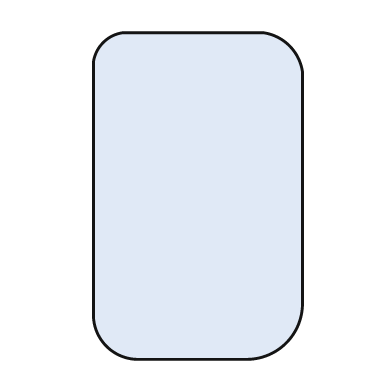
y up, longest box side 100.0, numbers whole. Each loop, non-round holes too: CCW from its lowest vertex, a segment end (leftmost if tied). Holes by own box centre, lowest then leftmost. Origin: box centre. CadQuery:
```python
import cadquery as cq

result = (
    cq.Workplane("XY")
    .moveTo(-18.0, -50.0)
    .lineTo(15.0, -50.0)
    .threePointArc((27.0, -45.0), (32.0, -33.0))
    .lineTo(32.0, 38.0)
    .threePointArc((28.0, 46.0), (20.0, 50.0))
    .lineTo(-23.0, 50.0)
    .threePointArc((-29.0, 47.0), (-32.0, 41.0))
    .lineTo(-32.0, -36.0)
    .threePointArc((-28.0, -46.0), (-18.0, -50.0))
    .close()
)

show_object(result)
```